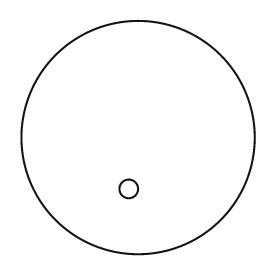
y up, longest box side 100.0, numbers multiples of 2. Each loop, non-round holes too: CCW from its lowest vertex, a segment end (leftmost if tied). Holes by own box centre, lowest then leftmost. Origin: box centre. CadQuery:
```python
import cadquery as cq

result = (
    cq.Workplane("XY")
    .moveTo(0.0, 0.0)
    .circle(50.0)
    .moveTo(-4.0, -22.0)
    .circle(4.0)
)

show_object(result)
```